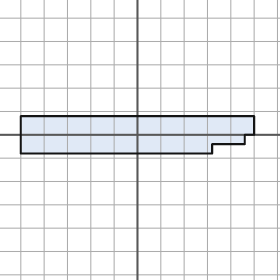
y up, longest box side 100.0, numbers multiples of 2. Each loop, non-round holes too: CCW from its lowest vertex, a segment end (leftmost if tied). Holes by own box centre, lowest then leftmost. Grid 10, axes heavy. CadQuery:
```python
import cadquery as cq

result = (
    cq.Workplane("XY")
    .moveTo(-50.0, -8.0)
    .lineTo(32.0, -8.0)
    .lineTo(32.0, -4.0)
    .lineTo(46.0, -4.0)
    .lineTo(46.0, 0.0)
    .lineTo(50.0, 0.0)
    .lineTo(50.0, 8.0)
    .lineTo(-50.0, 8.0)
    .close()
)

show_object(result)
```